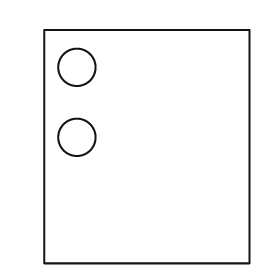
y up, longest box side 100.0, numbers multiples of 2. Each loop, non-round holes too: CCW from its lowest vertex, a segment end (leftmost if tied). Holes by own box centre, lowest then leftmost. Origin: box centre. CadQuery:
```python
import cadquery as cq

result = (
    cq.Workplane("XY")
    .moveTo(-44.0, -50.0)
    .lineTo(44.0, -50.0)
    .lineTo(44.0, 50.0)
    .lineTo(-44.0, 50.0)
    .close()
    .moveTo(-30.0, 4.0)
    .circle(8.0)
    .moveTo(-30.0, 34.0)
    .circle(8.0)
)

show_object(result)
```